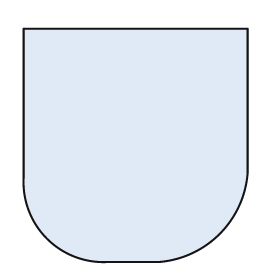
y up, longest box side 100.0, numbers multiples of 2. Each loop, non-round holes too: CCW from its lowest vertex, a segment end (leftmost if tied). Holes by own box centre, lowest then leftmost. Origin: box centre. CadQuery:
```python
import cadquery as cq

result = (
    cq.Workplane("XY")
    .moveTo(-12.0, -50.0)
    .lineTo(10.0, -50.0)
    .threePointArc((36.0, -38.0), (48.0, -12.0))
    .lineTo(48.0, 50.0)
    .lineTo(-48.0, 50.0)
    .lineTo(-48.0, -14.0)
    .threePointArc((-38.0, -40.0), (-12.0, -50.0))
    .close()
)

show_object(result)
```